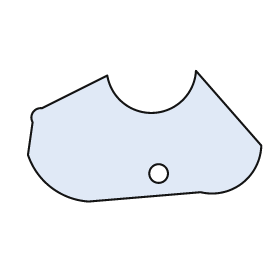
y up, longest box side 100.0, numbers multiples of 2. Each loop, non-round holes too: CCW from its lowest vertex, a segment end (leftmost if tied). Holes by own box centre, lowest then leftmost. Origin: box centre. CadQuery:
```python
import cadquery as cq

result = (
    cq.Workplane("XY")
    .moveTo(-24.0, -28.0)
    .lineTo(24.0, -24.0)
    .threePointArc((42.0, -20.0), (50.0, -4.0))
    .lineTo(22.0, 28.0)
    .threePointArc((4.0, 10.0), (-16.0, 26.0))
    .lineTo(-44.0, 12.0)
    .threePointArc((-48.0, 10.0), (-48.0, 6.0))
    .lineTo(-50.0, -8.0)
    .threePointArc((-40.0, -22.0), (-24.0, -28.0))
    .close()
    .moveTo(6.0, -16.0)
    .circle(4.0)
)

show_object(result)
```